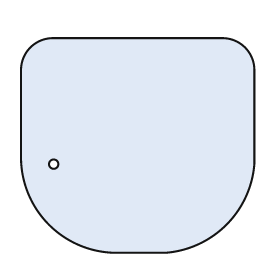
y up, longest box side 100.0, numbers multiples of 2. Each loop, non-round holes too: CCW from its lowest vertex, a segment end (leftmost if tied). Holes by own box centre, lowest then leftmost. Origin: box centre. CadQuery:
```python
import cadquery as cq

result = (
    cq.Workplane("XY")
    .moveTo(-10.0, -46.0)
    .lineTo(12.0, -46.0)
    .threePointArc((38.0, -34.0), (50.0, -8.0))
    .lineTo(50.0, 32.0)
    .threePointArc((46.0, 42.0), (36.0, 46.0))
    .lineTo(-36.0, 46.0)
    .threePointArc((-46.0, 42.0), (-50.0, 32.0))
    .lineTo(-50.0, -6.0)
    .threePointArc((-38.0, -34.0), (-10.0, -46.0))
    .close()
    .moveTo(-36.0, -8.0)
    .circle(2.0)
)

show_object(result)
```